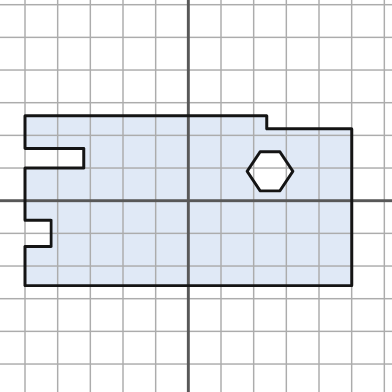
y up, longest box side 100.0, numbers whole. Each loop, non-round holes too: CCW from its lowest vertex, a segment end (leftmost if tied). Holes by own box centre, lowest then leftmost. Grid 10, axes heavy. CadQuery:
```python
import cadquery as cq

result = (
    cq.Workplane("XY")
    .moveTo(-50.0, -26.0)
    .lineTo(50.0, -26.0)
    .lineTo(50.0, 22.0)
    .lineTo(24.0, 22.0)
    .lineTo(24.0, 26.0)
    .lineTo(-50.0, 26.0)
    .lineTo(-50.0, 16.0)
    .lineTo(-32.0, 16.0)
    .lineTo(-32.0, 10.0)
    .lineTo(-50.0, 10.0)
    .lineTo(-50.0, -6.0)
    .lineTo(-42.0, -6.0)
    .lineTo(-42.0, -14.0)
    .lineTo(-50.0, -14.0)
    .close()
    .moveTo(22.0, 3.0)
    .lineTo(28.0, 3.0)
    .lineTo(32.0, 9.0)
    .lineTo(28.0, 15.0)
    .lineTo(22.0, 15.0)
    .lineTo(18.0, 9.0)
    .close()
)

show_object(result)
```